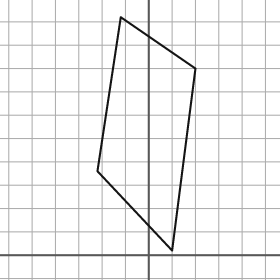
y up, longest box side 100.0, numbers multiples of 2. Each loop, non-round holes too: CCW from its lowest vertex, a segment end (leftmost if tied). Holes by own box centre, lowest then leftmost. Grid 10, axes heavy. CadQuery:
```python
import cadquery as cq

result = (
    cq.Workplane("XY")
    .moveTo(10.0, 2.0)
    .lineTo(20.0, 80.0)
    .lineTo(-12.0, 102.0)
    .lineTo(-22.0, 36.0)
    .close()
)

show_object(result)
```